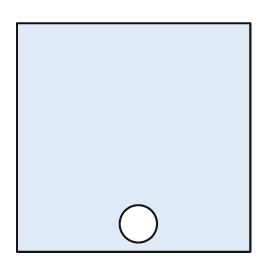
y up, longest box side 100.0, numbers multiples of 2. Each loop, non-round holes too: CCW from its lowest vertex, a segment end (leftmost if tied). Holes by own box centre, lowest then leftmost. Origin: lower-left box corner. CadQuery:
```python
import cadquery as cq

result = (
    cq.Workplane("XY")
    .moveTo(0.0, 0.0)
    .lineTo(100.0, 0.0)
    .lineTo(100.0, 98.0)
    .lineTo(0.0, 98.0)
    .close()
    .moveTo(52.0, 12.0)
    .circle(8.0)
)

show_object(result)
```